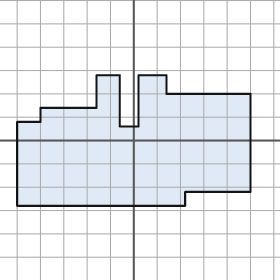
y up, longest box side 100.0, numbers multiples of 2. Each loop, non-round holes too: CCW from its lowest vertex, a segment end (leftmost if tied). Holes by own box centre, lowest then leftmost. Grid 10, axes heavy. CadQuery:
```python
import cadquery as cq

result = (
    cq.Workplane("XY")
    .moveTo(-50.0, -28.0)
    .lineTo(22.0, -28.0)
    .lineTo(22.0, -22.0)
    .lineTo(50.0, -22.0)
    .lineTo(50.0, 20.0)
    .lineTo(14.0, 20.0)
    .lineTo(14.0, 28.0)
    .lineTo(2.0, 28.0)
    .lineTo(2.0, 6.0)
    .lineTo(-6.0, 6.0)
    .lineTo(-6.0, 28.0)
    .lineTo(-16.0, 28.0)
    .lineTo(-16.0, 14.0)
    .lineTo(-40.0, 14.0)
    .lineTo(-40.0, 8.0)
    .lineTo(-50.0, 8.0)
    .close()
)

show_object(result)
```